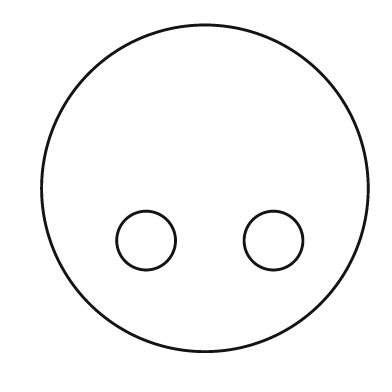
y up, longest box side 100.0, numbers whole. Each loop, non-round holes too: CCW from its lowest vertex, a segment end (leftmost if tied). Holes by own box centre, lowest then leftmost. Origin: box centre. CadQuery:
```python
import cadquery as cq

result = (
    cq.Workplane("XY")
    .moveTo(0.0, 0.0)
    .circle(50.0)
    .moveTo(-18.0, -16.0)
    .circle(9.0)
    .moveTo(21.0, -16.0)
    .circle(9.0)
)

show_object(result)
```